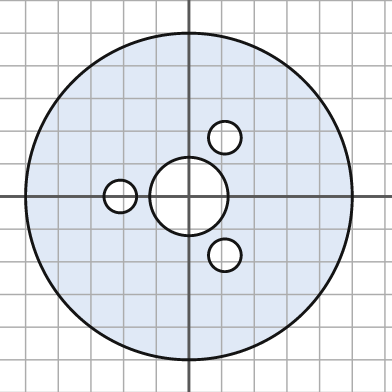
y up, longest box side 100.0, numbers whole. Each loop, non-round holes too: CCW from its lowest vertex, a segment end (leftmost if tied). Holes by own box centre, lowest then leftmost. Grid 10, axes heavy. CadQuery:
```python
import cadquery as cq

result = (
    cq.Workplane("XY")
    .moveTo(0.0, 0.0)
    .circle(50.0)
    .moveTo(11.0, -18.0)
    .circle(5.0)
    .moveTo(-21.0, 0.0)
    .circle(5.0)
    .moveTo(0.0, 0.0)
    .circle(12.0)
    .moveTo(11.0, 18.0)
    .circle(5.0)
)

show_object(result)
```